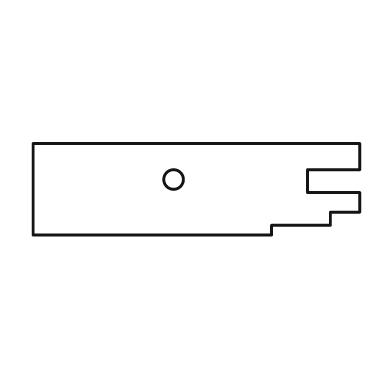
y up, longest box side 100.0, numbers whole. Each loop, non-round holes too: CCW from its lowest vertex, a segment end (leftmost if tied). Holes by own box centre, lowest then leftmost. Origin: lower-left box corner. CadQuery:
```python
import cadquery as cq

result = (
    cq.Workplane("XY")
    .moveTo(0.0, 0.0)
    .lineTo(73.0, 0.0)
    .lineTo(73.0, 3.0)
    .lineTo(91.0, 3.0)
    .lineTo(91.0, 7.0)
    .lineTo(100.0, 7.0)
    .lineTo(100.0, 13.0)
    .lineTo(84.0, 13.0)
    .lineTo(84.0, 20.0)
    .lineTo(100.0, 20.0)
    .lineTo(100.0, 28.0)
    .lineTo(0.0, 28.0)
    .close()
    .moveTo(43.0, 17.0)
    .circle(3.0)
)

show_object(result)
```